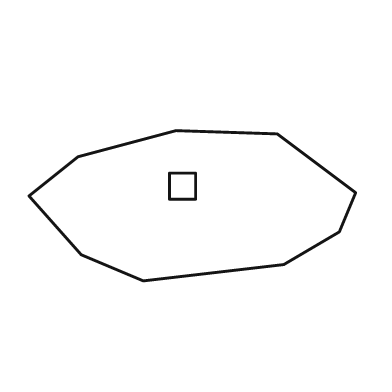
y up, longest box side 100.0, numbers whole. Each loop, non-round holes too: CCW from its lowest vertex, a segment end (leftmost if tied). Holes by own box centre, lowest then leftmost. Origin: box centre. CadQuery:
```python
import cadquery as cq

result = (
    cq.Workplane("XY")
    .moveTo(-15.0, -23.0)
    .lineTo(28.0, -18.0)
    .lineTo(45.0, -8.0)
    .lineTo(50.0, 4.0)
    .lineTo(26.0, 22.0)
    .lineTo(-5.0, 23.0)
    .lineTo(-35.0, 15.0)
    .lineTo(-50.0, 3.0)
    .lineTo(-34.0, -15.0)
    .close()
    .moveTo(-7.0, 2.0)
    .lineTo(1.0, 2.0)
    .lineTo(1.0, 10.0)
    .lineTo(-7.0, 10.0)
    .close()
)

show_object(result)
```